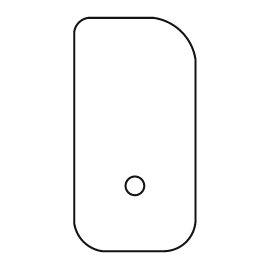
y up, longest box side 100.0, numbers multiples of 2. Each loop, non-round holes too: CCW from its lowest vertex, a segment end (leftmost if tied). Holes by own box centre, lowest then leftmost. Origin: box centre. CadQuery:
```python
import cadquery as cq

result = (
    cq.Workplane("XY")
    .moveTo(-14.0, -50.0)
    .lineTo(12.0, -50.0)
    .threePointArc((22.0, -46.0), (26.0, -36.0))
    .lineTo(26.0, 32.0)
    .threePointArc((20.0, 44.0), (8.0, 50.0))
    .lineTo(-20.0, 50.0)
    .threePointArc((-24.0, 48.0), (-26.0, 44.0))
    .lineTo(-26.0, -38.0)
    .threePointArc((-22.0, -46.0), (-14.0, -50.0))
    .close()
    .moveTo(0.0, -22.0)
    .circle(4.0)
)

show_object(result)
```